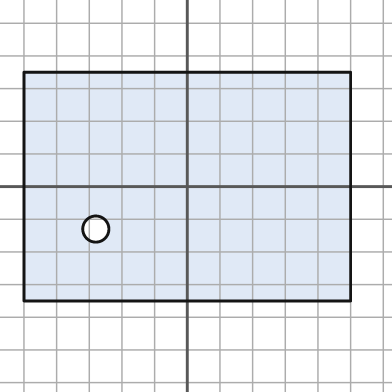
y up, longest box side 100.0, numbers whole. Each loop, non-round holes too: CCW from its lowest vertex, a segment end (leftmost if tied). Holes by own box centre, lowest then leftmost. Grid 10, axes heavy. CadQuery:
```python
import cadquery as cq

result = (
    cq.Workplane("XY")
    .moveTo(-50.0, -35.0)
    .lineTo(50.0, -35.0)
    .lineTo(50.0, 35.0)
    .lineTo(-50.0, 35.0)
    .close()
    .moveTo(-28.0, -13.0)
    .circle(4.0)
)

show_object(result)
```